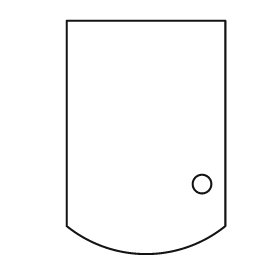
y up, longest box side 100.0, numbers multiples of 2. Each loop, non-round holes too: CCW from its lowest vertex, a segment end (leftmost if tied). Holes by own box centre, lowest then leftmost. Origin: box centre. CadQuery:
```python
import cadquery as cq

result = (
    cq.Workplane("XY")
    .moveTo(-34.0, -38.0)
    .threePointArc((0.0, -50.0), (34.0, -38.0))
    .lineTo(34.0, 50.0)
    .lineTo(-34.0, 50.0)
    .close()
    .moveTo(24.0, -20.0)
    .circle(4.0)
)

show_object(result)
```